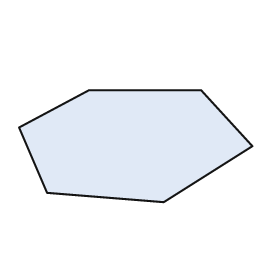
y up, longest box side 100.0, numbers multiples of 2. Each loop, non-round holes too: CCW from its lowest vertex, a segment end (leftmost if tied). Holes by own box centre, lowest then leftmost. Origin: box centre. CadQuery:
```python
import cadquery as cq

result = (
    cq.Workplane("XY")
    .moveTo(12.0, -24.0)
    .lineTo(50.0, 0.0)
    .lineTo(28.0, 24.0)
    .lineTo(-20.0, 24.0)
    .lineTo(-50.0, 8.0)
    .lineTo(-38.0, -20.0)
    .close()
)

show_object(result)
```